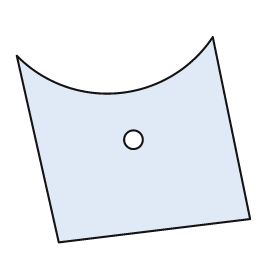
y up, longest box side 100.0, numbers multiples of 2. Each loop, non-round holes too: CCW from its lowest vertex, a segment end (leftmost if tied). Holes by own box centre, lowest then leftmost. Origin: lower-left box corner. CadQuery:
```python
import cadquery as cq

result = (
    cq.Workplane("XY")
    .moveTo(18.0, 0.0)
    .lineTo(100.0, 10.0)
    .lineTo(84.0, 88.0)
    .threePointArc((44.0, 64.0), (0.0, 80.0))
    .close()
    .moveTo(50.0, 44.0)
    .circle(4.0)
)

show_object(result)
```